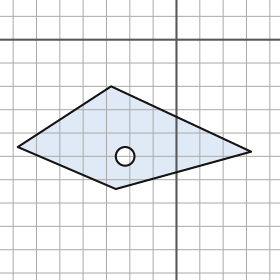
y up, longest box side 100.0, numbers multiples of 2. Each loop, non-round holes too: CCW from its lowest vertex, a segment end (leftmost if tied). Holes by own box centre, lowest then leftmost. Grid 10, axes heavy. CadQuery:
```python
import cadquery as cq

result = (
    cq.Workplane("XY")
    .moveTo(-26.0, -64.0)
    .lineTo(32.0, -48.0)
    .lineTo(-28.0, -20.0)
    .lineTo(-68.0, -46.0)
    .close()
    .moveTo(-22.0, -50.0)
    .circle(4.0)
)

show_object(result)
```